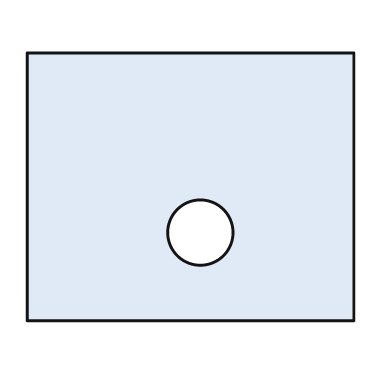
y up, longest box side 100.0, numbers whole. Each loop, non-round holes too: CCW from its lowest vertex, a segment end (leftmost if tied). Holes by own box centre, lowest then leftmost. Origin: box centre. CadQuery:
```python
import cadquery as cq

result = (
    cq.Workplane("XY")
    .moveTo(-50.0, -41.0)
    .lineTo(50.0, -41.0)
    .lineTo(50.0, 41.0)
    .lineTo(-50.0, 41.0)
    .close()
    .moveTo(3.0, -14.0)
    .circle(10.0)
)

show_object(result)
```